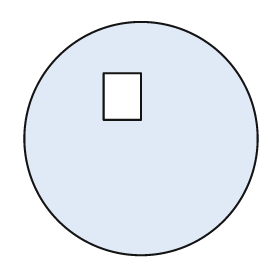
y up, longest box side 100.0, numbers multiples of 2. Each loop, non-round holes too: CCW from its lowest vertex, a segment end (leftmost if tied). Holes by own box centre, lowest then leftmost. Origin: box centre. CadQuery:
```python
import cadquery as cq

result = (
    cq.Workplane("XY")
    .moveTo(0.0, 0.0)
    .circle(50.0)
    .moveTo(-16.0, 8.0)
    .lineTo(0.0, 8.0)
    .lineTo(0.0, 28.0)
    .lineTo(-16.0, 28.0)
    .close()
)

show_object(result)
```